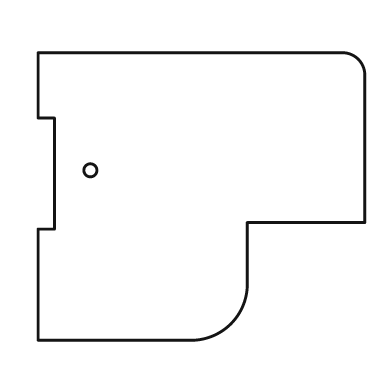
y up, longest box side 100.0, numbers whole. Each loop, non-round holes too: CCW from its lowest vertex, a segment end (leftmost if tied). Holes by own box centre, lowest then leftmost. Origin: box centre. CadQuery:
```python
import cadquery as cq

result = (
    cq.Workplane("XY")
    .moveTo(-50.0, -44.0)
    .lineTo(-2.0, -44.0)
    .threePointArc((9.0, -39.0), (14.0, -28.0))
    .lineTo(14.0, -8.0)
    .lineTo(50.0, -8.0)
    .lineTo(50.0, 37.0)
    .threePointArc((48.0, 42.0), (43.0, 44.0))
    .lineTo(-50.0, 44.0)
    .lineTo(-50.0, 24.0)
    .lineTo(-45.0, 24.0)
    .lineTo(-45.0, -10.0)
    .lineTo(-50.0, -10.0)
    .close()
    .moveTo(-34.0, 8.0)
    .circle(2.0)
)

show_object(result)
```